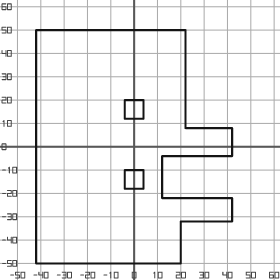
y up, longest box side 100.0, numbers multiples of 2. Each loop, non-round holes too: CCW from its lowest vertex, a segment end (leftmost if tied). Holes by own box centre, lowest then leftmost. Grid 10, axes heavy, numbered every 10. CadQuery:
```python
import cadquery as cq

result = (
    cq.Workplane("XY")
    .moveTo(-42.0, -50.0)
    .lineTo(20.0, -50.0)
    .lineTo(20.0, -32.0)
    .lineTo(42.0, -32.0)
    .lineTo(42.0, -22.0)
    .lineTo(12.0, -22.0)
    .lineTo(12.0, -4.0)
    .lineTo(42.0, -4.0)
    .lineTo(42.0, 8.0)
    .lineTo(22.0, 8.0)
    .lineTo(22.0, 50.0)
    .lineTo(-42.0, 50.0)
    .close()
    .moveTo(-4.0, -18.0)
    .lineTo(4.0, -18.0)
    .lineTo(4.0, -10.0)
    .lineTo(-4.0, -10.0)
    .close()
    .moveTo(-4.0, 12.0)
    .lineTo(4.0, 12.0)
    .lineTo(4.0, 20.0)
    .lineTo(-4.0, 20.0)
    .close()
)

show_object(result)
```